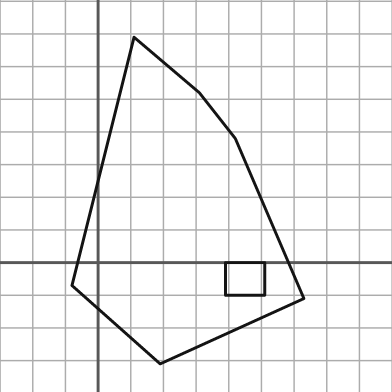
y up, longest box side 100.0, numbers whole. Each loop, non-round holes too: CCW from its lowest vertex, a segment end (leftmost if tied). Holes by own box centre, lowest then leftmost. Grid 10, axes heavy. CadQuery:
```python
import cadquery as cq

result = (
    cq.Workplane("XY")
    .moveTo(19.0, -31.0)
    .lineTo(63.0, -11.0)
    .lineTo(42.0, 38.0)
    .lineTo(31.0, 52.0)
    .lineTo(11.0, 69.0)
    .lineTo(-8.0, -7.0)
    .close()
    .moveTo(39.0, -10.0)
    .lineTo(51.0, -10.0)
    .lineTo(51.0, 0.0)
    .lineTo(39.0, 0.0)
    .close()
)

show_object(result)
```